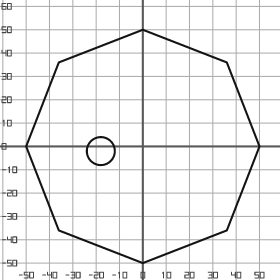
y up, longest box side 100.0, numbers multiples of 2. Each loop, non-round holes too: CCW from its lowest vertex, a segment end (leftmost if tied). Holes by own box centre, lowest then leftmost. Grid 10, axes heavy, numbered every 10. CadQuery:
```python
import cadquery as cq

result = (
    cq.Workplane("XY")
    .moveTo(0.0, -50.0)
    .lineTo(36.0, -36.0)
    .lineTo(50.0, 0.0)
    .lineTo(36.0, 36.0)
    .lineTo(0.0, 50.0)
    .lineTo(-36.0, 36.0)
    .lineTo(-50.0, 0.0)
    .lineTo(-36.0, -36.0)
    .close()
    .moveTo(-18.0, -2.0)
    .circle(6.0)
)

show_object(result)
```